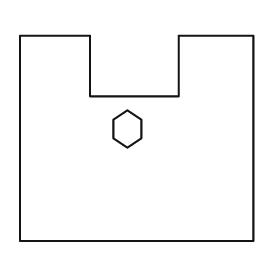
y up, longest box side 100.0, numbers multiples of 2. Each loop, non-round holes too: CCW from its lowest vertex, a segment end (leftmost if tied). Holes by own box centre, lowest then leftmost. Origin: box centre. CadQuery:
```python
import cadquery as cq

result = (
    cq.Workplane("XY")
    .moveTo(-50.0, -44.0)
    .lineTo(50.0, -44.0)
    .lineTo(50.0, 44.0)
    .lineTo(18.0, 44.0)
    .lineTo(18.0, 18.0)
    .lineTo(-20.0, 18.0)
    .lineTo(-20.0, 44.0)
    .lineTo(-50.0, 44.0)
    .close()
    .moveTo(-4.0, -4.0)
    .lineTo(2.0, 0.0)
    .lineTo(2.0, 8.0)
    .lineTo(-4.0, 12.0)
    .lineTo(-10.0, 8.0)
    .lineTo(-10.0, 0.0)
    .close()
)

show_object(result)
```